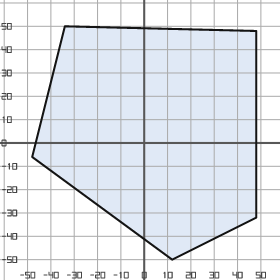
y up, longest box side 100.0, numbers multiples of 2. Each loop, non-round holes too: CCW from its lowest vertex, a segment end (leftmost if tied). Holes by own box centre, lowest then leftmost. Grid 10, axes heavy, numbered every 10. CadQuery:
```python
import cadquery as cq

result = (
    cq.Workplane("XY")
    .moveTo(12.0, -50.0)
    .lineTo(48.0, -32.0)
    .lineTo(48.0, 48.0)
    .lineTo(-34.0, 50.0)
    .lineTo(-48.0, -6.0)
    .close()
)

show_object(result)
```